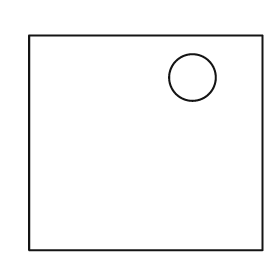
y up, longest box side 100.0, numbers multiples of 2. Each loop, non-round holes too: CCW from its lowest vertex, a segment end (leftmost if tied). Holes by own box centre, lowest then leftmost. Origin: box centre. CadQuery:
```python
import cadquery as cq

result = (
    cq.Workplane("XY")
    .moveTo(-50.0, -46.0)
    .lineTo(50.0, -46.0)
    .lineTo(50.0, 46.0)
    .lineTo(-50.0, 46.0)
    .close()
    .moveTo(20.0, 28.0)
    .circle(10.0)
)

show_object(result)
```